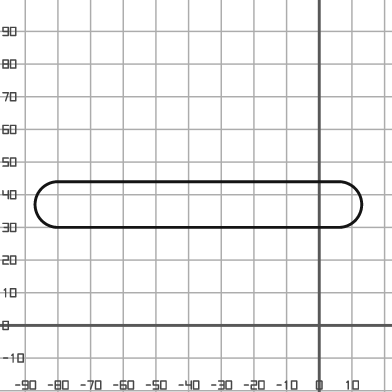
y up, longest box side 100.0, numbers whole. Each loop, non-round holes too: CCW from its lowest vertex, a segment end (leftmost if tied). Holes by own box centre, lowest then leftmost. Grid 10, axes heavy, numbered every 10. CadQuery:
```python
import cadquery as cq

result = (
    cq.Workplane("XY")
    .moveTo(-80.0, 30.0)
    .lineTo(6.0, 30.0)
    .threePointArc((13.0, 37.0), (6.0, 44.0))
    .lineTo(-80.0, 44.0)
    .threePointArc((-87.0, 37.0), (-80.0, 30.0))
    .close()
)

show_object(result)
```